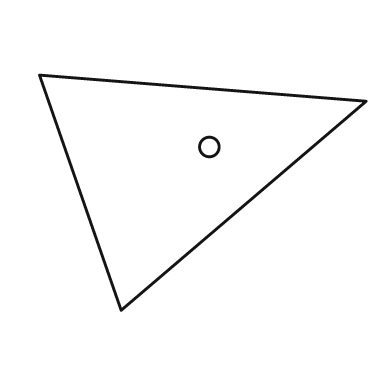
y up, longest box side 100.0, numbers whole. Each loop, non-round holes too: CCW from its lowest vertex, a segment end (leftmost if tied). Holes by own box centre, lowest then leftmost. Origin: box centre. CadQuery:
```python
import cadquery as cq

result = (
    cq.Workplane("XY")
    .moveTo(-25.0, -36.0)
    .lineTo(50.0, 28.0)
    .lineTo(-50.0, 36.0)
    .close()
    .moveTo(2.0, 14.0)
    .circle(3.0)
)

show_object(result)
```